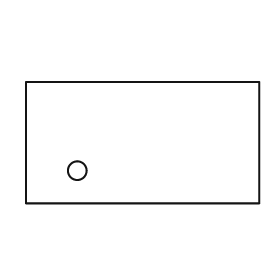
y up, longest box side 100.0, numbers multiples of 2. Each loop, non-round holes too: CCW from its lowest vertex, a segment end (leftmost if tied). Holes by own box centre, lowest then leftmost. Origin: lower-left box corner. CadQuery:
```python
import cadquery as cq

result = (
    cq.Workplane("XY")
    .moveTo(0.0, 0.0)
    .lineTo(100.0, 0.0)
    .lineTo(100.0, 52.0)
    .lineTo(0.0, 52.0)
    .close()
    .moveTo(22.0, 14.0)
    .circle(4.0)
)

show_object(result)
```